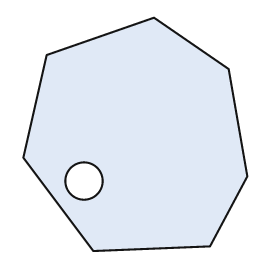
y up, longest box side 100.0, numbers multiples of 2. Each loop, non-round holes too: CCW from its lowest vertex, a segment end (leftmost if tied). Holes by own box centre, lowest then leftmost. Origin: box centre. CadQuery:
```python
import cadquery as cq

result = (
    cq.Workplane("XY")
    .moveTo(-18.0, -50.0)
    .lineTo(32.0, -48.0)
    .lineTo(48.0, -18.0)
    .lineTo(40.0, 28.0)
    .lineTo(8.0, 50.0)
    .lineTo(-38.0, 34.0)
    .lineTo(-48.0, -10.0)
    .close()
    .moveTo(-22.0, -20.0)
    .circle(8.0)
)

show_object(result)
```